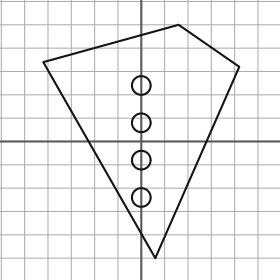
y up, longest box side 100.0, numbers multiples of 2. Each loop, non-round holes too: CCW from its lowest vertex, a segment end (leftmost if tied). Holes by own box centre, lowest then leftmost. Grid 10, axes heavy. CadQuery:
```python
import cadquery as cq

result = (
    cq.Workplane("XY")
    .moveTo(6.0, -50.0)
    .lineTo(42.0, 32.0)
    .lineTo(16.0, 50.0)
    .lineTo(-42.0, 34.0)
    .close()
    .moveTo(0.0, -24.0)
    .circle(4.0)
    .moveTo(0.0, -8.0)
    .circle(4.0)
    .moveTo(0.0, 8.0)
    .circle(4.0)
    .moveTo(0.0, 24.0)
    .circle(4.0)
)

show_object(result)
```